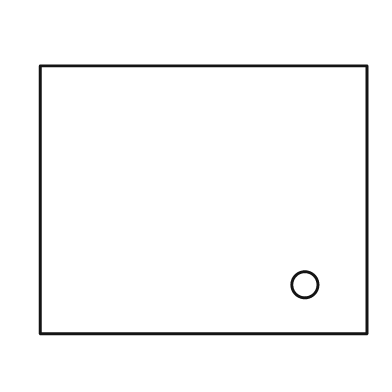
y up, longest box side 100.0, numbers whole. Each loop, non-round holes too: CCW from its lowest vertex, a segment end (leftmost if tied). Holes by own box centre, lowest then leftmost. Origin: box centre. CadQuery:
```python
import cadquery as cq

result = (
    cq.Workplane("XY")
    .moveTo(-50.0, -41.0)
    .lineTo(50.0, -41.0)
    .lineTo(50.0, 41.0)
    .lineTo(-50.0, 41.0)
    .close()
    .moveTo(31.0, -26.0)
    .circle(4.0)
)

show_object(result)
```